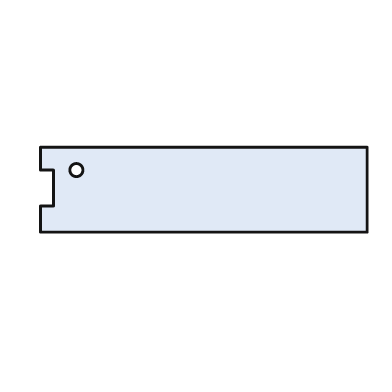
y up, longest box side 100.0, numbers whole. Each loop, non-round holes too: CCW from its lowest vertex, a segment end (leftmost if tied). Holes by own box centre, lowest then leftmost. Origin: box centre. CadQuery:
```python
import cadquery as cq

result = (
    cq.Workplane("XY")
    .moveTo(-50.0, -13.0)
    .lineTo(50.0, -13.0)
    .lineTo(50.0, 13.0)
    .lineTo(-50.0, 13.0)
    .lineTo(-50.0, 6.0)
    .lineTo(-46.0, 6.0)
    .lineTo(-46.0, -5.0)
    .lineTo(-50.0, -5.0)
    .close()
    .moveTo(-39.0, 6.0)
    .circle(2.0)
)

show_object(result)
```